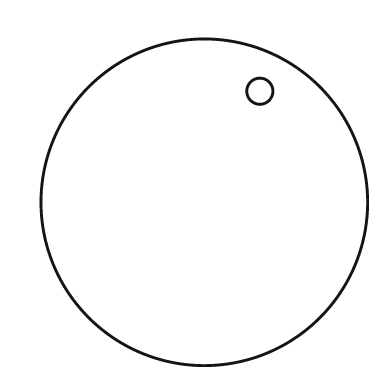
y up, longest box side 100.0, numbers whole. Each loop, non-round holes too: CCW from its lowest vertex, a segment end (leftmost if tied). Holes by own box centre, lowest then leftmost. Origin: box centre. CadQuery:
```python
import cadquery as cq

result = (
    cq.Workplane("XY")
    .moveTo(0.0, 0.0)
    .circle(50.0)
    .moveTo(17.0, 34.0)
    .circle(4.0)
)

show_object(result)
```